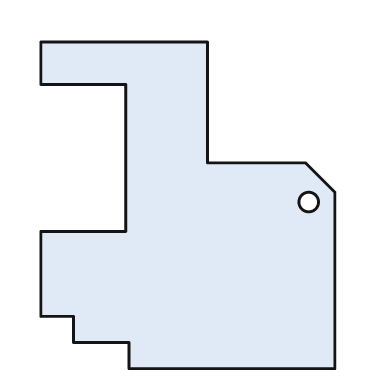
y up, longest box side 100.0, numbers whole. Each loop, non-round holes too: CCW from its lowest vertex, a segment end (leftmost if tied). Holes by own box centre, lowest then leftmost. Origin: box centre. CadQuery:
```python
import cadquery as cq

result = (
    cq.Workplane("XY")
    .moveTo(-18.0, -50.0)
    .lineTo(45.0, -50.0)
    .lineTo(45.0, 4.0)
    .lineTo(36.0, 13.0)
    .lineTo(6.0, 13.0)
    .lineTo(6.0, 50.0)
    .lineTo(-45.0, 50.0)
    .lineTo(-45.0, 37.0)
    .lineTo(-19.0, 37.0)
    .lineTo(-19.0, -8.0)
    .lineTo(-45.0, -8.0)
    .lineTo(-45.0, -34.0)
    .lineTo(-35.0, -34.0)
    .lineTo(-35.0, -42.0)
    .lineTo(-18.0, -42.0)
    .close()
    .moveTo(37.0, 1.0)
    .circle(3.0)
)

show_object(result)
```